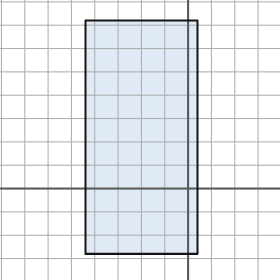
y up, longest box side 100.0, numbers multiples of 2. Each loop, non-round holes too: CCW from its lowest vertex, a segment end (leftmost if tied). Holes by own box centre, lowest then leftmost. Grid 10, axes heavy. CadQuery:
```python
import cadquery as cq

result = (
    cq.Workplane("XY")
    .moveTo(-44.0, -28.0)
    .lineTo(4.0, -28.0)
    .lineTo(4.0, 72.0)
    .lineTo(-44.0, 72.0)
    .close()
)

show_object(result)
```